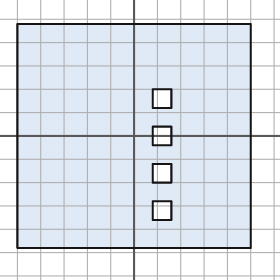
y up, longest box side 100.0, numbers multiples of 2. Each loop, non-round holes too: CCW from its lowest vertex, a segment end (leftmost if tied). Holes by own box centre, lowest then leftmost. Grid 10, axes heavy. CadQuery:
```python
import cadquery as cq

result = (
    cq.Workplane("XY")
    .moveTo(-50.0, -48.0)
    .lineTo(50.0, -48.0)
    .lineTo(50.0, 48.0)
    .lineTo(-50.0, 48.0)
    .close()
    .moveTo(8.0, -36.0)
    .lineTo(16.0, -36.0)
    .lineTo(16.0, -28.0)
    .lineTo(8.0, -28.0)
    .close()
    .moveTo(8.0, -20.0)
    .lineTo(16.0, -20.0)
    .lineTo(16.0, -12.0)
    .lineTo(8.0, -12.0)
    .close()
    .moveTo(8.0, -4.0)
    .lineTo(16.0, -4.0)
    .lineTo(16.0, 4.0)
    .lineTo(8.0, 4.0)
    .close()
    .moveTo(8.0, 12.0)
    .lineTo(16.0, 12.0)
    .lineTo(16.0, 20.0)
    .lineTo(8.0, 20.0)
    .close()
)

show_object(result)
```